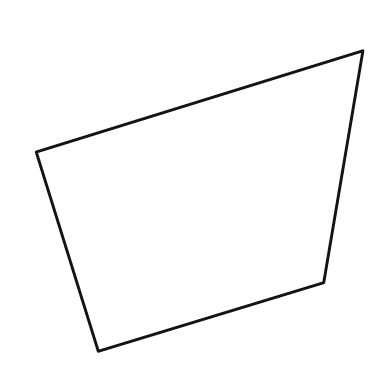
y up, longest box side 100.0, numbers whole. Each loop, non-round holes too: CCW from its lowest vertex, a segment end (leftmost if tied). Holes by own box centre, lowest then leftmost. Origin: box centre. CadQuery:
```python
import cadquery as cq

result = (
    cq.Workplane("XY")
    .moveTo(-31.0, -46.0)
    .lineTo(38.0, -25.0)
    .lineTo(50.0, 46.0)
    .lineTo(-50.0, 15.0)
    .close()
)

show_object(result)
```